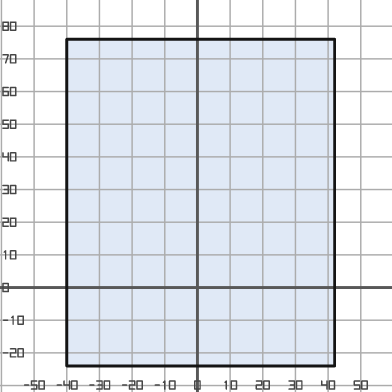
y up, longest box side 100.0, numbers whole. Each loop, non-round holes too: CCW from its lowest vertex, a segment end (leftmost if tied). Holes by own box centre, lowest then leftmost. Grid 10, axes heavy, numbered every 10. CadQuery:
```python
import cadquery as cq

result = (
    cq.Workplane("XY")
    .moveTo(-40.0, -24.0)
    .lineTo(42.0, -24.0)
    .lineTo(42.0, 76.0)
    .lineTo(-40.0, 76.0)
    .close()
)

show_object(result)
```